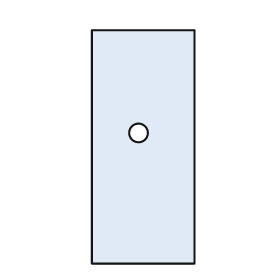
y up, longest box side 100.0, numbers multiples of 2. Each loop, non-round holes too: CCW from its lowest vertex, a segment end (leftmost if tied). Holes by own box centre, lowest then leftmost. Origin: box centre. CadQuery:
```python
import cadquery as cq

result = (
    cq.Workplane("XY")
    .moveTo(-22.0, -50.0)
    .lineTo(22.0, -50.0)
    .lineTo(22.0, 50.0)
    .lineTo(-22.0, 50.0)
    .close()
    .moveTo(-2.0, 6.0)
    .circle(4.0)
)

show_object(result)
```